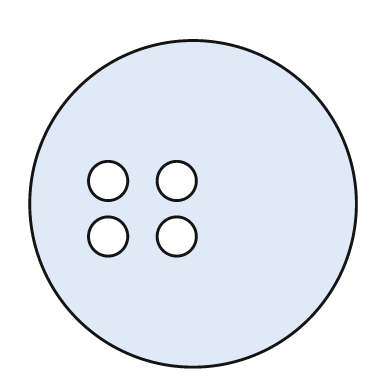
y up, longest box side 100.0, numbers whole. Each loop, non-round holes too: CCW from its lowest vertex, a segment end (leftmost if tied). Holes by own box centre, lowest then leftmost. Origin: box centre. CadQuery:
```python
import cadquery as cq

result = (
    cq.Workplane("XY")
    .moveTo(0.0, 0.0)
    .circle(50.0)
    .moveTo(-26.0, -10.0)
    .circle(6.0)
    .moveTo(-5.0, -10.0)
    .circle(6.0)
    .moveTo(-26.0, 7.0)
    .circle(6.0)
    .moveTo(-5.0, 7.0)
    .circle(6.0)
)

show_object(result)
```